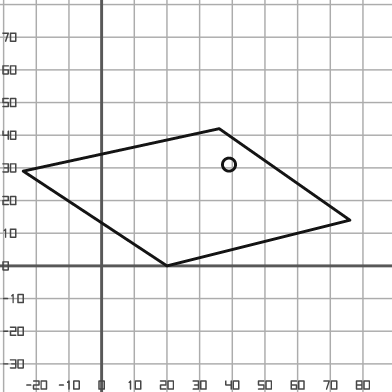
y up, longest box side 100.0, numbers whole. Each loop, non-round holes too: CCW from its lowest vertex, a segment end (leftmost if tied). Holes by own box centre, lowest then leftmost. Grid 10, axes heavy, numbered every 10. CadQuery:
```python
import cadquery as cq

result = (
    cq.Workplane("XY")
    .moveTo(20.0, 0.0)
    .lineTo(76.0, 14.0)
    .lineTo(36.0, 42.0)
    .lineTo(-24.0, 29.0)
    .close()
    .moveTo(39.0, 31.0)
    .circle(2.0)
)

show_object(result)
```